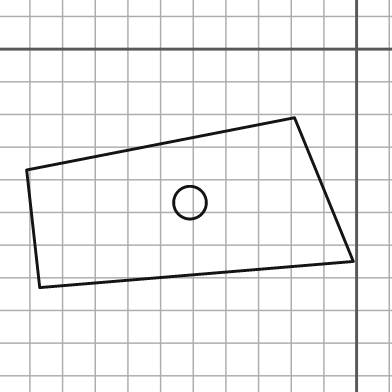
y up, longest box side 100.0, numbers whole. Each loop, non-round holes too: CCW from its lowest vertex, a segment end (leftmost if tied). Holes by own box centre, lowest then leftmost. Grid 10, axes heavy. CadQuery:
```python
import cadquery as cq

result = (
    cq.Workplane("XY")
    .moveTo(-97.0, -73.0)
    .lineTo(-1.0, -65.0)
    .lineTo(-19.0, -21.0)
    .lineTo(-101.0, -37.0)
    .close()
    .moveTo(-51.0, -47.0)
    .circle(5.0)
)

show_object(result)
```